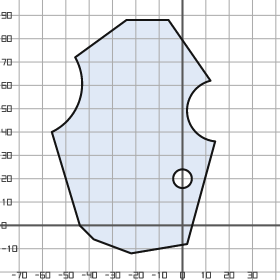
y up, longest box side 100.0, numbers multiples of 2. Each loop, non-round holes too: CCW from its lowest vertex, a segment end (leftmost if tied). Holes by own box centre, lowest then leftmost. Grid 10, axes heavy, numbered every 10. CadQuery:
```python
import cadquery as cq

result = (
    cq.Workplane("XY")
    .moveTo(-22.0, -12.0)
    .lineTo(2.0, -8.0)
    .lineTo(14.0, 36.0)
    .threePointArc((2.0, 48.0), (12.0, 62.0))
    .lineTo(-6.0, 88.0)
    .lineTo(-24.0, 88.0)
    .lineTo(-46.0, 72.0)
    .threePointArc((-44.0, 54.0), (-56.0, 40.0))
    .lineTo(-44.0, 0.0)
    .lineTo(-38.0, -6.0)
    .close()
    .moveTo(0.0, 20.0)
    .circle(4.0)
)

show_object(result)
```